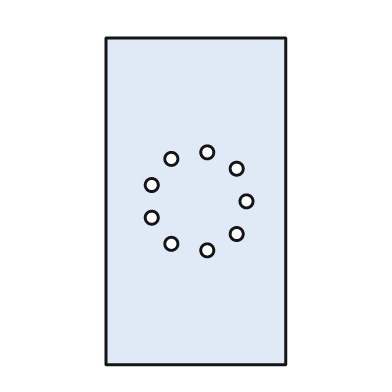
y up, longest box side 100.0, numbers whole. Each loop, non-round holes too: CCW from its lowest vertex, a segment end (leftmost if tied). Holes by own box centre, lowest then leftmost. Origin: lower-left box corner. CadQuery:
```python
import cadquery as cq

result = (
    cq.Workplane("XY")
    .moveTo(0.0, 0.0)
    .lineTo(55.0, 0.0)
    .lineTo(55.0, 100.0)
    .lineTo(0.0, 100.0)
    .close()
    .moveTo(31.0, 35.0)
    .circle(2.0)
    .moveTo(20.0, 37.0)
    .circle(2.0)
    .moveTo(40.0, 40.0)
    .circle(2.0)
    .moveTo(14.0, 45.0)
    .circle(2.0)
    .moveTo(43.0, 50.0)
    .circle(2.0)
    .moveTo(14.0, 55.0)
    .circle(2.0)
    .moveTo(40.0, 60.0)
    .circle(2.0)
    .moveTo(20.0, 63.0)
    .circle(2.0)
    .moveTo(31.0, 65.0)
    .circle(2.0)
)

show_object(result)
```